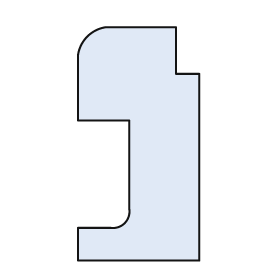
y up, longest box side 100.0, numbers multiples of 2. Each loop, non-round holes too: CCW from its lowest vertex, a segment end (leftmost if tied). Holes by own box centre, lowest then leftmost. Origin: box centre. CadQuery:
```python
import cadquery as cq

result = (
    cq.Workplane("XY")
    .moveTo(-26.0, -50.0)
    .lineTo(26.0, -50.0)
    .lineTo(26.0, 30.0)
    .lineTo(16.0, 30.0)
    .lineTo(16.0, 50.0)
    .lineTo(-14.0, 50.0)
    .threePointArc((-22.0, 46.0), (-26.0, 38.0))
    .lineTo(-26.0, 10.0)
    .lineTo(-4.0, 10.0)
    .lineTo(-4.0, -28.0)
    .threePointArc((-6.0, -34.0), (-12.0, -36.0))
    .lineTo(-26.0, -36.0)
    .close()
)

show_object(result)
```